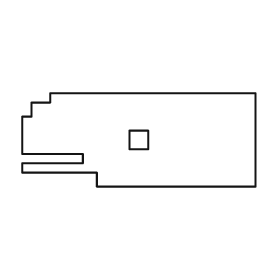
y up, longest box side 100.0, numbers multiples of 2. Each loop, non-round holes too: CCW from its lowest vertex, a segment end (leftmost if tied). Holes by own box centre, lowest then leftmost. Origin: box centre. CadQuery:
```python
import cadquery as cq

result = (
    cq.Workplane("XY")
    .moveTo(-18.0, -20.0)
    .lineTo(50.0, -20.0)
    .lineTo(50.0, 20.0)
    .lineTo(-38.0, 20.0)
    .lineTo(-38.0, 16.0)
    .lineTo(-46.0, 16.0)
    .lineTo(-46.0, 10.0)
    .lineTo(-50.0, 10.0)
    .lineTo(-50.0, -6.0)
    .lineTo(-24.0, -6.0)
    .lineTo(-24.0, -10.0)
    .lineTo(-50.0, -10.0)
    .lineTo(-50.0, -14.0)
    .lineTo(-18.0, -14.0)
    .close()
    .moveTo(-4.0, -4.0)
    .lineTo(4.0, -4.0)
    .lineTo(4.0, 4.0)
    .lineTo(-4.0, 4.0)
    .close()
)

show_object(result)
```